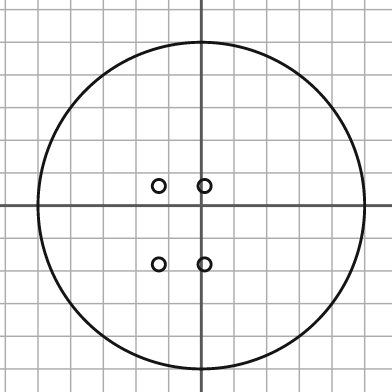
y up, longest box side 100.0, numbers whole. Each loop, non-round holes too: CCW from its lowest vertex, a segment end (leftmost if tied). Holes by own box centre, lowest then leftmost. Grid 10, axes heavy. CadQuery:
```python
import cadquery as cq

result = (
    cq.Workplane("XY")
    .moveTo(0.0, 0.0)
    .circle(50.0)
    .moveTo(-13.0, -18.0)
    .circle(2.0)
    .moveTo(1.0, -18.0)
    .circle(2.0)
    .moveTo(-13.0, 6.0)
    .circle(2.0)
    .moveTo(1.0, 6.0)
    .circle(2.0)
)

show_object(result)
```